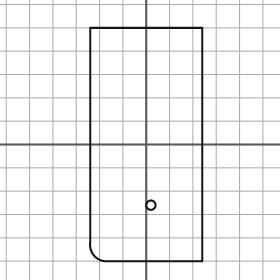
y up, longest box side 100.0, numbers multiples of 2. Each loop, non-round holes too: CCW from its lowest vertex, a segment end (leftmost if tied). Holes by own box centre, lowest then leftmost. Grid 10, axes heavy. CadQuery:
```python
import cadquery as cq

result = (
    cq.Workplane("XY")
    .moveTo(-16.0, -50.0)
    .lineTo(24.0, -50.0)
    .lineTo(24.0, 50.0)
    .lineTo(-24.0, 50.0)
    .lineTo(-24.0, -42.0)
    .threePointArc((-22.0, -48.0), (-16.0, -50.0))
    .close()
    .moveTo(2.0, -26.0)
    .circle(2.0)
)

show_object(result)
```